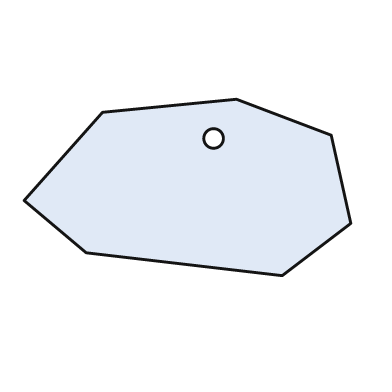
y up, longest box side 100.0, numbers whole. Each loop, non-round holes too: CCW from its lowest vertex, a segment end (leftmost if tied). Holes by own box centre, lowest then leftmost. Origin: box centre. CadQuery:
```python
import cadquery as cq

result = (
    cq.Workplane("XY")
    .moveTo(29.0, -27.0)
    .lineTo(50.0, -11.0)
    .lineTo(44.0, 16.0)
    .lineTo(15.0, 27.0)
    .lineTo(-26.0, 23.0)
    .lineTo(-50.0, -4.0)
    .lineTo(-31.0, -20.0)
    .close()
    .moveTo(8.0, 15.0)
    .circle(3.0)
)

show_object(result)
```